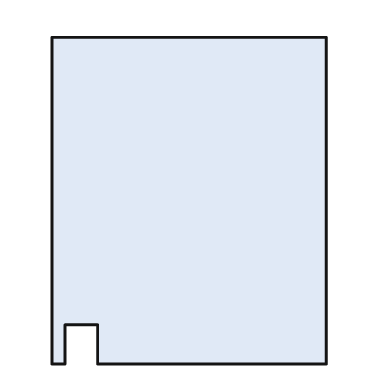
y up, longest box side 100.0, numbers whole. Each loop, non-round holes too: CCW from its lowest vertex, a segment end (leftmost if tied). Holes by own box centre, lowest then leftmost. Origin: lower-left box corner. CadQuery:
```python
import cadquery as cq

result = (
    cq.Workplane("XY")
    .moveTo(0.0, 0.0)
    .lineTo(4.0, 0.0)
    .lineTo(4.0, 12.0)
    .lineTo(14.0, 12.0)
    .lineTo(14.0, 0.0)
    .lineTo(84.0, 0.0)
    .lineTo(84.0, 100.0)
    .lineTo(0.0, 100.0)
    .close()
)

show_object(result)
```